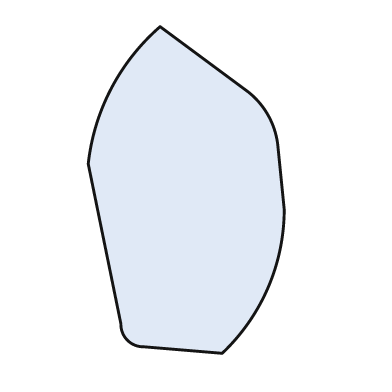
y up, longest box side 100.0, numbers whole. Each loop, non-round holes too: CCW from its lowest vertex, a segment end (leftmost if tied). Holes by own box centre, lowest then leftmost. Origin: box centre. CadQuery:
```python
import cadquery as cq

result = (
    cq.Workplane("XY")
    .moveTo(11.0, -50.0)
    .threePointArc((25.0, -30.0), (30.0, -6.0))
    .lineTo(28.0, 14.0)
    .threePointArc((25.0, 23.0), (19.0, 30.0))
    .lineTo(-8.0, 50.0)
    .threePointArc((-23.0, 31.0), (-30.0, 8.0))
    .lineTo(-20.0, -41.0)
    .threePointArc((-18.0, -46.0), (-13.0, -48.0))
    .close()
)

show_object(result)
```